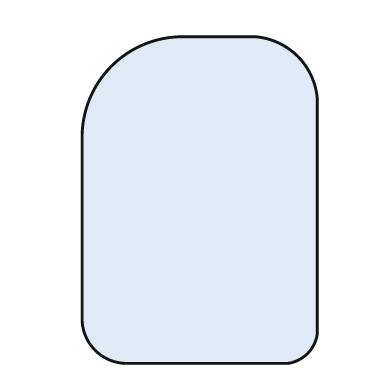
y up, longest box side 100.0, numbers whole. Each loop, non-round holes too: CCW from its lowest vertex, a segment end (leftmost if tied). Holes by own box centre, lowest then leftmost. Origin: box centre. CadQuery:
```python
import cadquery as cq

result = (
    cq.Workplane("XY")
    .moveTo(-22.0, -50.0)
    .lineTo(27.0, -50.0)
    .threePointArc((33.0, -47.0), (36.0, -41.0))
    .lineTo(36.0, 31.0)
    .threePointArc((30.0, 44.0), (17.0, 50.0))
    .lineTo(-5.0, 50.0)
    .threePointArc((-27.0, 41.0), (-36.0, 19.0))
    .lineTo(-36.0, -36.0)
    .threePointArc((-32.0, -46.0), (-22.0, -50.0))
    .close()
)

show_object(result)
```